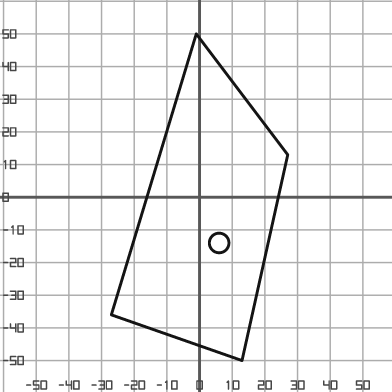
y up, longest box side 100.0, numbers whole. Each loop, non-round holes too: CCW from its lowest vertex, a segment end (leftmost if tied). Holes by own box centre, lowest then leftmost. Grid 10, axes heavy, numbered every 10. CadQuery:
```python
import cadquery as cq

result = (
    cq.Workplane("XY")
    .moveTo(13.0, -50.0)
    .lineTo(27.0, 13.0)
    .lineTo(-1.0, 50.0)
    .lineTo(-27.0, -36.0)
    .close()
    .moveTo(6.0, -14.0)
    .circle(3.0)
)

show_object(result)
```